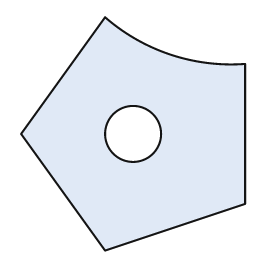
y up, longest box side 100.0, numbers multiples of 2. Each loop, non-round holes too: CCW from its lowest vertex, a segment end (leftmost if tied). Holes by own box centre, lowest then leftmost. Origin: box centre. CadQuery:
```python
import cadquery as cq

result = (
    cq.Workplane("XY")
    .moveTo(-12.0, -50.0)
    .lineTo(48.0, -30.0)
    .lineTo(48.0, 30.0)
    .threePointArc((16.0, 34.0), (-12.0, 50.0))
    .lineTo(-48.0, 0.0)
    .close()
    .moveTo(0.0, 0.0)
    .circle(12.0)
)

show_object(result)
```